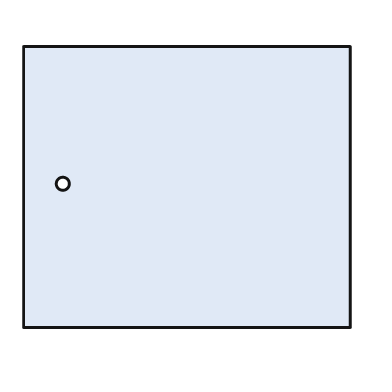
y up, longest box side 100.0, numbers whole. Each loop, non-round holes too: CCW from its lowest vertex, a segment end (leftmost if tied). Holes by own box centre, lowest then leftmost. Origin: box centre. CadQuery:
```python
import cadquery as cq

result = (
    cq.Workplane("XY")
    .moveTo(-50.0, -43.0)
    .lineTo(50.0, -43.0)
    .lineTo(50.0, 43.0)
    .lineTo(-50.0, 43.0)
    .close()
    .moveTo(-38.0, 1.0)
    .circle(2.0)
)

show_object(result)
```